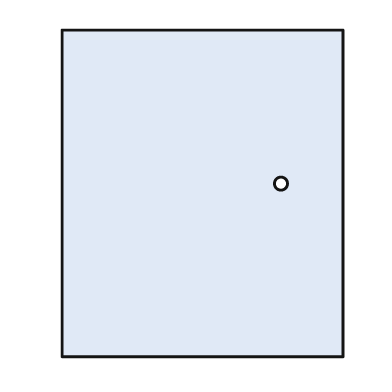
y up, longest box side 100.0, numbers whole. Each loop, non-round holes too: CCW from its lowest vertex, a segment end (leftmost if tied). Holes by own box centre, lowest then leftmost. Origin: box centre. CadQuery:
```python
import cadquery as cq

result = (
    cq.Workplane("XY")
    .moveTo(-43.0, -50.0)
    .lineTo(43.0, -50.0)
    .lineTo(43.0, 50.0)
    .lineTo(-43.0, 50.0)
    .close()
    .moveTo(24.0, 3.0)
    .circle(2.0)
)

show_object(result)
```